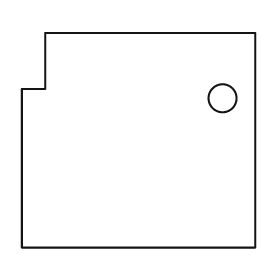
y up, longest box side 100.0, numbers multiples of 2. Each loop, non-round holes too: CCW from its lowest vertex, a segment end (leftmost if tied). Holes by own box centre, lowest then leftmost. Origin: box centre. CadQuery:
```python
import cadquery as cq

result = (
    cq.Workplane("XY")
    .moveTo(-50.0, -46.0)
    .lineTo(50.0, -46.0)
    .lineTo(50.0, 46.0)
    .lineTo(-40.0, 46.0)
    .lineTo(-40.0, 22.0)
    .lineTo(-50.0, 22.0)
    .close()
    .moveTo(36.0, 18.0)
    .circle(6.0)
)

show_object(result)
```